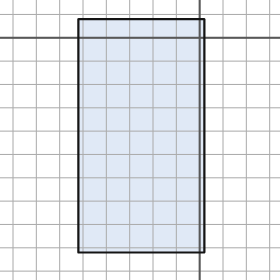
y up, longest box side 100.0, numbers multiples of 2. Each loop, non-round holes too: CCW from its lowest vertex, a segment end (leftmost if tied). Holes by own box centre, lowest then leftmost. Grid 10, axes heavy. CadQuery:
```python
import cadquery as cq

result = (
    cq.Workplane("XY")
    .moveTo(-52.0, -92.0)
    .lineTo(2.0, -92.0)
    .lineTo(2.0, 8.0)
    .lineTo(-52.0, 8.0)
    .close()
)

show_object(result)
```